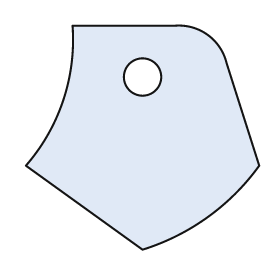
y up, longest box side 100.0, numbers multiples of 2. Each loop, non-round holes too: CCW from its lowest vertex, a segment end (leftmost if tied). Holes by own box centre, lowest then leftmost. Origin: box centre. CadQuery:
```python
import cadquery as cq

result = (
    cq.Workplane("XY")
    .moveTo(0.0, -48.0)
    .threePointArc((28.0, -34.0), (50.0, -12.0))
    .lineTo(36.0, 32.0)
    .threePointArc((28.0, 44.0), (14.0, 48.0))
    .lineTo(-30.0, 48.0)
    .threePointArc((-34.0, 16.0), (-50.0, -12.0))
    .close()
    .moveTo(0.0, 26.0)
    .circle(8.0)
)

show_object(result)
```